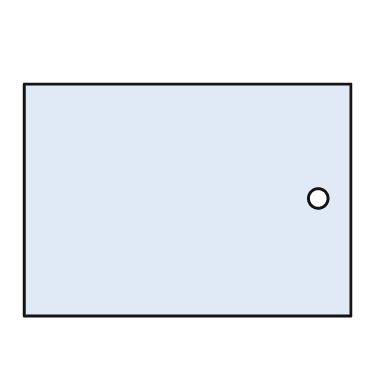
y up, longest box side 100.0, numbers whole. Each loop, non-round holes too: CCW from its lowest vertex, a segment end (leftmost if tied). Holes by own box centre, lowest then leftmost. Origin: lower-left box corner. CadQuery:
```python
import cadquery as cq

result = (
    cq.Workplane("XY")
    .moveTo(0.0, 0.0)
    .lineTo(100.0, 0.0)
    .lineTo(100.0, 71.0)
    .lineTo(0.0, 71.0)
    .close()
    .moveTo(90.0, 36.0)
    .circle(3.0)
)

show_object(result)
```